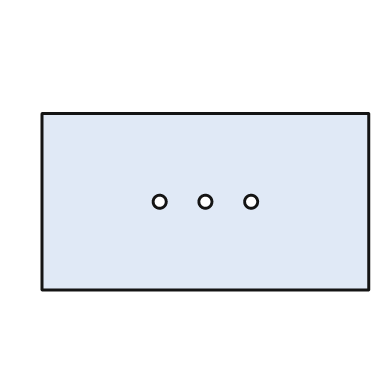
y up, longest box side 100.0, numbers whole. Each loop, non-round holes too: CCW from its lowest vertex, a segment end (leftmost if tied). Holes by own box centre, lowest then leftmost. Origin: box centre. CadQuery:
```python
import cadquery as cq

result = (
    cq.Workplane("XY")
    .moveTo(-50.0, -27.0)
    .lineTo(50.0, -27.0)
    .lineTo(50.0, 27.0)
    .lineTo(-50.0, 27.0)
    .close()
    .moveTo(-14.0, 0.0)
    .circle(2.0)
    .moveTo(0.0, 0.0)
    .circle(2.0)
    .moveTo(14.0, 0.0)
    .circle(2.0)
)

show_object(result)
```